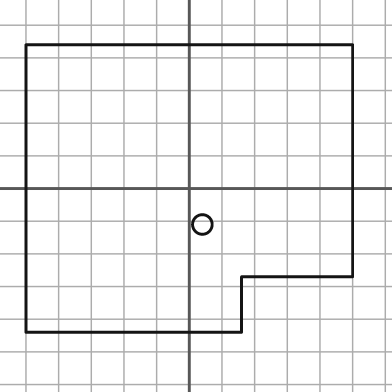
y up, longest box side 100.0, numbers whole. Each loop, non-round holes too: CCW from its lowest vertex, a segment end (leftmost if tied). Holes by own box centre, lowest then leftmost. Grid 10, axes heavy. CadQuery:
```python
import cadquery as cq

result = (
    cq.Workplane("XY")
    .moveTo(-50.0, -44.0)
    .lineTo(16.0, -44.0)
    .lineTo(16.0, -27.0)
    .lineTo(50.0, -27.0)
    .lineTo(50.0, 44.0)
    .lineTo(-50.0, 44.0)
    .close()
    .moveTo(4.0, -11.0)
    .circle(3.0)
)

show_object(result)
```